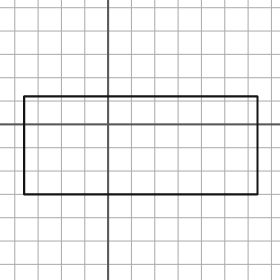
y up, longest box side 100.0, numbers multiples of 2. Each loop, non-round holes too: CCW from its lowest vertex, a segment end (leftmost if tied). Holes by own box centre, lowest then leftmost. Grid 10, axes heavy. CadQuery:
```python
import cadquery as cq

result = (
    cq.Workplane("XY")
    .moveTo(-36.0, -30.0)
    .lineTo(64.0, -30.0)
    .lineTo(64.0, 12.0)
    .lineTo(-36.0, 12.0)
    .close()
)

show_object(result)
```